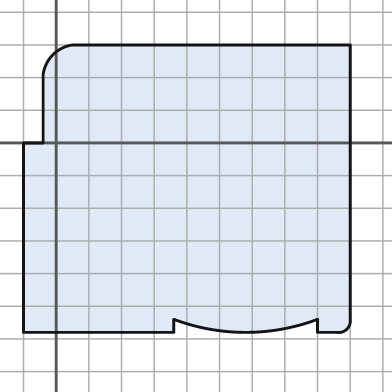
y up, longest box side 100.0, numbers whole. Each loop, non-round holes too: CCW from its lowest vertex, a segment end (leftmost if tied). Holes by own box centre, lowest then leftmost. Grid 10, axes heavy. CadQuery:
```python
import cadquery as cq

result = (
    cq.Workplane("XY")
    .moveTo(-10.0, -58.0)
    .lineTo(36.0, -58.0)
    .lineTo(36.0, -54.0)
    .threePointArc((58.0, -58.0), (80.0, -54.0))
    .lineTo(80.0, -58.0)
    .lineTo(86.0, -58.0)
    .threePointArc((89.0, -57.0), (90.0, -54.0))
    .lineTo(90.0, 30.0)
    .lineTo(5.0, 30.0)
    .threePointArc((-1.0, 27.0), (-4.0, 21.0))
    .lineTo(-4.0, 0.0)
    .lineTo(-10.0, 0.0)
    .close()
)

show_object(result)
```